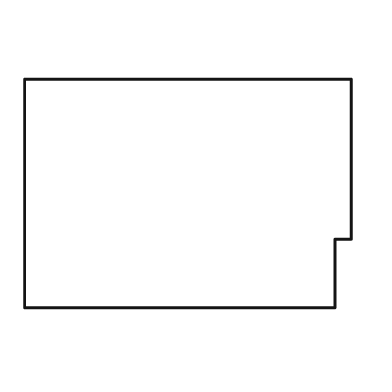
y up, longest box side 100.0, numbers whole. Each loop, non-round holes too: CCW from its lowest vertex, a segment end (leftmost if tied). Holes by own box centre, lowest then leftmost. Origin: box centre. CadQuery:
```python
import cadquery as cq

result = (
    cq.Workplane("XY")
    .moveTo(-50.0, -35.0)
    .lineTo(45.0, -35.0)
    .lineTo(45.0, -14.0)
    .lineTo(50.0, -14.0)
    .lineTo(50.0, 35.0)
    .lineTo(-50.0, 35.0)
    .close()
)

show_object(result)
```